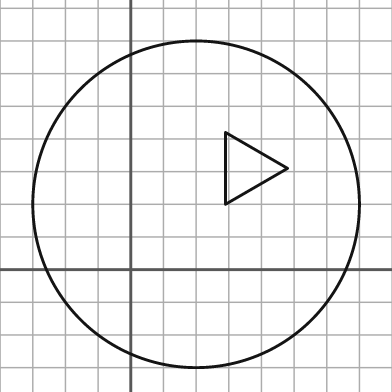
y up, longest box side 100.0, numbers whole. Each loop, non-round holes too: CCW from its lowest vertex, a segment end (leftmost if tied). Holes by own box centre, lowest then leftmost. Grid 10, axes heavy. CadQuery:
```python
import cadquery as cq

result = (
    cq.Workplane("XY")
    .moveTo(20.0, 20.0)
    .circle(50.0)
    .moveTo(29.0, 20.0)
    .lineTo(48.0, 31.0)
    .lineTo(29.0, 42.0)
    .close()
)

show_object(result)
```